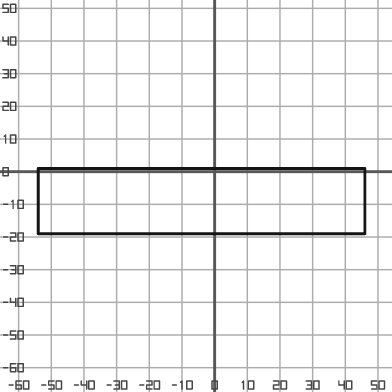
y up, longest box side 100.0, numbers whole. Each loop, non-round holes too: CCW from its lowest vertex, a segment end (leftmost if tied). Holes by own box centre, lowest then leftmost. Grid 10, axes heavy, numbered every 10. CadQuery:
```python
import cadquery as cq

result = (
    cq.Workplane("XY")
    .moveTo(-54.0, -19.0)
    .lineTo(46.0, -19.0)
    .lineTo(46.0, 1.0)
    .lineTo(-54.0, 1.0)
    .close()
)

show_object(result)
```